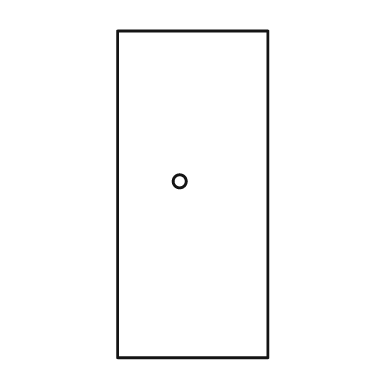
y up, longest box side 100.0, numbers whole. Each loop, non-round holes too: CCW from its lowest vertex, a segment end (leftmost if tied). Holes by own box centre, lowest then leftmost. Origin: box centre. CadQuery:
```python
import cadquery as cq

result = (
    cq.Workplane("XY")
    .moveTo(-23.0, -50.0)
    .lineTo(23.0, -50.0)
    .lineTo(23.0, 50.0)
    .lineTo(-23.0, 50.0)
    .close()
    .moveTo(-4.0, 4.0)
    .circle(2.0)
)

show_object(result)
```